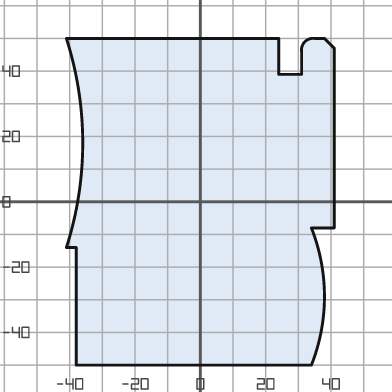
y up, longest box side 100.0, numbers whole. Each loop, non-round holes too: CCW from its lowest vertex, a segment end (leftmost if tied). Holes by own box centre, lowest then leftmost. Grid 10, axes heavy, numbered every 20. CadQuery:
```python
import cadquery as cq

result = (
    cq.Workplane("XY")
    .moveTo(-38.0, -50.0)
    .lineTo(34.0, -50.0)
    .threePointArc((38.0, -29.0), (34.0, -8.0))
    .lineTo(41.0, -8.0)
    .lineTo(41.0, 47.0)
    .lineTo(38.0, 50.0)
    .lineTo(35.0, 50.0)
    .threePointArc((32.0, 49.0), (31.0, 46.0))
    .lineTo(31.0, 39.0)
    .lineTo(24.0, 39.0)
    .lineTo(24.0, 50.0)
    .lineTo(-41.0, 50.0)
    .threePointArc((-36.0, 18.0), (-41.0, -14.0))
    .lineTo(-38.0, -14.0)
    .close()
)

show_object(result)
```